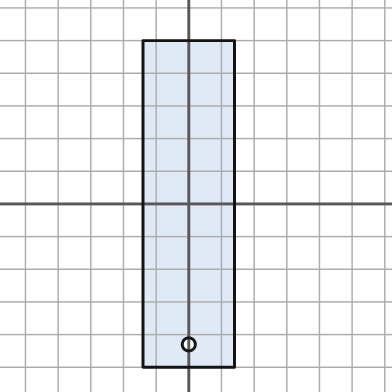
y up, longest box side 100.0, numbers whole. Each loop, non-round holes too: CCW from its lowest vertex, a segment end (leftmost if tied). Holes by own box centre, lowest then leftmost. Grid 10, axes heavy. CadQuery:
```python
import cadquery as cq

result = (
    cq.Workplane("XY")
    .moveTo(-14.0, -50.0)
    .lineTo(14.0, -50.0)
    .lineTo(14.0, 50.0)
    .lineTo(-14.0, 50.0)
    .close()
    .moveTo(0.0, -43.0)
    .circle(2.0)
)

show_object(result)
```